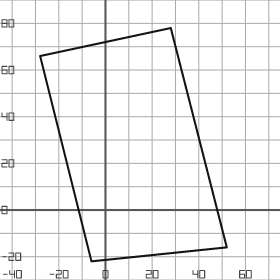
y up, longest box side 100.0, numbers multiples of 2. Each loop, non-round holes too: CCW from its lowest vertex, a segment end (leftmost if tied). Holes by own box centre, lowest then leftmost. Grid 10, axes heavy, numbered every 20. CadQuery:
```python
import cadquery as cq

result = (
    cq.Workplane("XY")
    .moveTo(-6.0, -22.0)
    .lineTo(52.0, -16.0)
    .lineTo(28.0, 78.0)
    .lineTo(-28.0, 66.0)
    .close()
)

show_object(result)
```